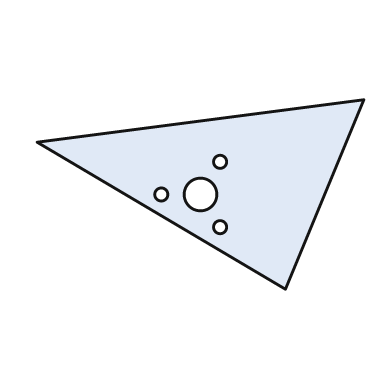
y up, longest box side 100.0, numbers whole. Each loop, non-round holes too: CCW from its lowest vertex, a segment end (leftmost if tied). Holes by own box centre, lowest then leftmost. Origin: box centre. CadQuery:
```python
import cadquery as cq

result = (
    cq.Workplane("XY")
    .moveTo(26.0, -29.0)
    .lineTo(50.0, 29.0)
    .lineTo(-50.0, 16.0)
    .close()
    .moveTo(6.0, -10.0)
    .circle(2.0)
    .moveTo(-12.0, 0.0)
    .circle(2.0)
    .moveTo(0.0, 0.0)
    .circle(5.0)
    .moveTo(6.0, 10.0)
    .circle(2.0)
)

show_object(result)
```